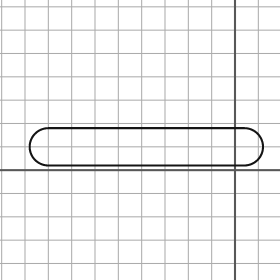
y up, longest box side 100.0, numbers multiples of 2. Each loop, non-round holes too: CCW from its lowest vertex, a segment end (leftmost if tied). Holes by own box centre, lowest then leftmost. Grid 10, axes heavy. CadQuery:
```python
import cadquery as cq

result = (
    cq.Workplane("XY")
    .moveTo(-80.0, 2.0)
    .lineTo(4.0, 2.0)
    .threePointArc((12.0, 10.0), (4.0, 18.0))
    .lineTo(-80.0, 18.0)
    .threePointArc((-88.0, 10.0), (-80.0, 2.0))
    .close()
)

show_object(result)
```